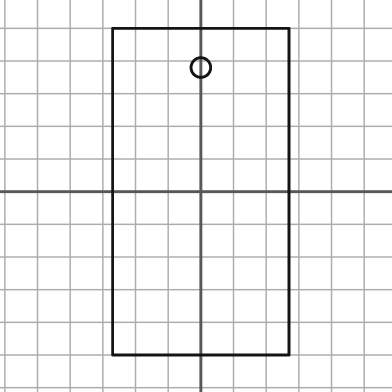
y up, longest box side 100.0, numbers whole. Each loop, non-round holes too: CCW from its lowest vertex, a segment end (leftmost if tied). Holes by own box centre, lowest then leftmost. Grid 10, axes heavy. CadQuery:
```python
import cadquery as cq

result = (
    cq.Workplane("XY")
    .moveTo(-27.0, -50.0)
    .lineTo(27.0, -50.0)
    .lineTo(27.0, 50.0)
    .lineTo(-27.0, 50.0)
    .close()
    .moveTo(0.0, 38.0)
    .circle(3.0)
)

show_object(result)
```